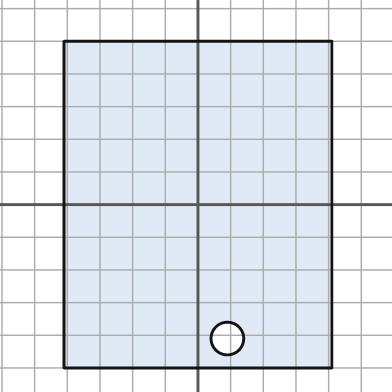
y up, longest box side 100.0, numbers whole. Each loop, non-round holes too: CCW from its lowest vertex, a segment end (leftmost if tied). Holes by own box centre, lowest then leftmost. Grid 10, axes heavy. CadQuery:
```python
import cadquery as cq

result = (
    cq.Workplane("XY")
    .moveTo(-41.0, -50.0)
    .lineTo(41.0, -50.0)
    .lineTo(41.0, 50.0)
    .lineTo(-41.0, 50.0)
    .close()
    .moveTo(9.0, -41.0)
    .circle(5.0)
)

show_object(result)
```